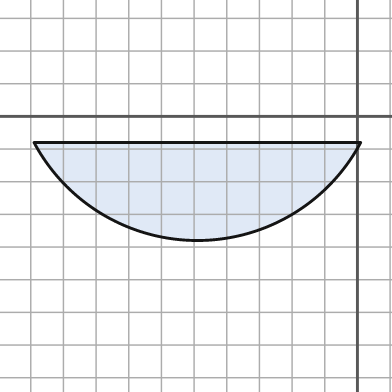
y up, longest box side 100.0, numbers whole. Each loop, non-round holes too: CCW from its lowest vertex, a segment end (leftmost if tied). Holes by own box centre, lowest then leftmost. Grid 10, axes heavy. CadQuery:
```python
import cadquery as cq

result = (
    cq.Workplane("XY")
    .moveTo(-99.0, -8.0)
    .threePointArc((-49.0, -38.0), (1.0, -8.0))
    .close()
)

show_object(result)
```